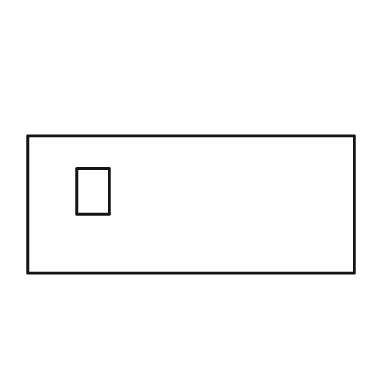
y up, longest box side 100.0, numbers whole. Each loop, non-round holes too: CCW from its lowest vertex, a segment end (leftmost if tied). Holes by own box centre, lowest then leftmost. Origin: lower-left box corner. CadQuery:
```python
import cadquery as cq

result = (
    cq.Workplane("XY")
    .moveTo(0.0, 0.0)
    .lineTo(100.0, 0.0)
    .lineTo(100.0, 42.0)
    .lineTo(0.0, 42.0)
    .close()
    .moveTo(15.0, 18.0)
    .lineTo(25.0, 18.0)
    .lineTo(25.0, 32.0)
    .lineTo(15.0, 32.0)
    .close()
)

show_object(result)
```